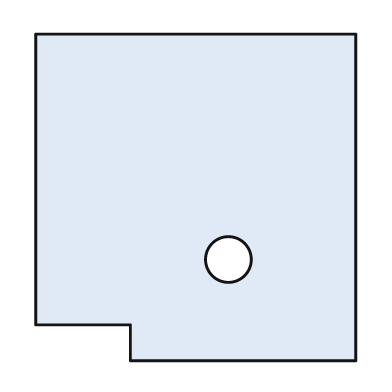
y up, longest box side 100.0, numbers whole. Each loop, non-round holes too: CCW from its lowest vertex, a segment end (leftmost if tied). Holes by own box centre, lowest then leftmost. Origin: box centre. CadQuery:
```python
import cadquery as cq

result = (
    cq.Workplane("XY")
    .moveTo(-20.0, -50.0)
    .lineTo(49.0, -50.0)
    .lineTo(49.0, 50.0)
    .lineTo(-49.0, 50.0)
    .lineTo(-49.0, -39.0)
    .lineTo(-20.0, -39.0)
    .close()
    .moveTo(10.0, -19.0)
    .circle(7.0)
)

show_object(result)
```